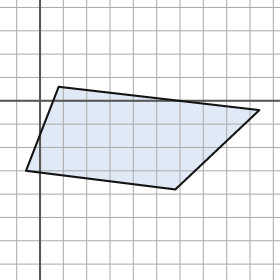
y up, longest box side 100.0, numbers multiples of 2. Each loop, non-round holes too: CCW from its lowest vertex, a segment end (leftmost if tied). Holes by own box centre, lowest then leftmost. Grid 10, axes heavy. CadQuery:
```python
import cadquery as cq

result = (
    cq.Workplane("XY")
    .moveTo(58.0, -38.0)
    .lineTo(94.0, -4.0)
    .lineTo(8.0, 6.0)
    .lineTo(-6.0, -30.0)
    .close()
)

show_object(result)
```